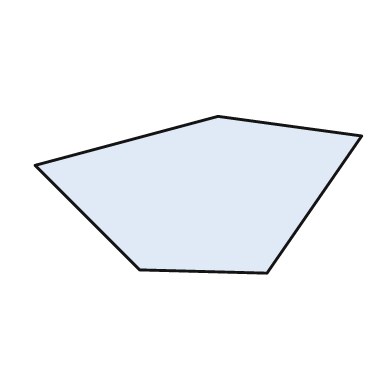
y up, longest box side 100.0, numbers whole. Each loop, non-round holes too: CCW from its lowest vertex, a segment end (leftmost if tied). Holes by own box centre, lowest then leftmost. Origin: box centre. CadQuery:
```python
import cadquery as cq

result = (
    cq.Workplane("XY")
    .moveTo(21.0, -24.0)
    .lineTo(50.0, 18.0)
    .lineTo(6.0, 24.0)
    .lineTo(-50.0, 9.0)
    .lineTo(-18.0, -23.0)
    .close()
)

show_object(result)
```